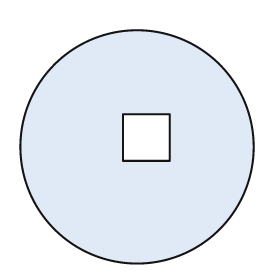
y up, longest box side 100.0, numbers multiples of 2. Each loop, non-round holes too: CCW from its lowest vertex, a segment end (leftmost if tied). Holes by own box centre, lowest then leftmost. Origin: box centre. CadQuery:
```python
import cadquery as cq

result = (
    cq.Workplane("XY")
    .moveTo(0.0, 0.0)
    .circle(50.0)
    .moveTo(-6.0, -6.0)
    .lineTo(14.0, -6.0)
    .lineTo(14.0, 14.0)
    .lineTo(-6.0, 14.0)
    .close()
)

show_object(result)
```